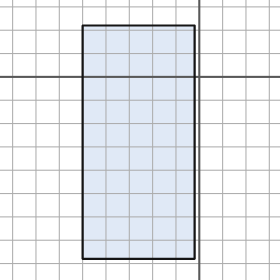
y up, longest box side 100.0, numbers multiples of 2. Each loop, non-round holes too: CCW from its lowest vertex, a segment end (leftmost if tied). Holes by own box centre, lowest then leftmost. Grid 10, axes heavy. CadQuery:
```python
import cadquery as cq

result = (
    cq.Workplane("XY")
    .moveTo(-50.0, -78.0)
    .lineTo(-2.0, -78.0)
    .lineTo(-2.0, 22.0)
    .lineTo(-50.0, 22.0)
    .close()
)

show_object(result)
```